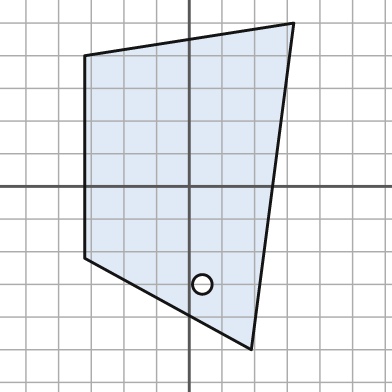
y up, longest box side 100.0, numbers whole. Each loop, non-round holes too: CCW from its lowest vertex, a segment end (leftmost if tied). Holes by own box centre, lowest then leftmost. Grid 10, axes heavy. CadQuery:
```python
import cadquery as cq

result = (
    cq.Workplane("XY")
    .moveTo(19.0, -50.0)
    .lineTo(32.0, 50.0)
    .lineTo(-32.0, 40.0)
    .lineTo(-32.0, -22.0)
    .close()
    .moveTo(4.0, -30.0)
    .circle(3.0)
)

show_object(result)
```